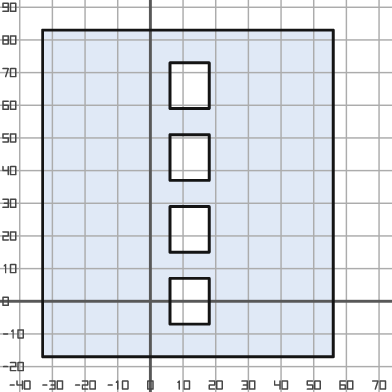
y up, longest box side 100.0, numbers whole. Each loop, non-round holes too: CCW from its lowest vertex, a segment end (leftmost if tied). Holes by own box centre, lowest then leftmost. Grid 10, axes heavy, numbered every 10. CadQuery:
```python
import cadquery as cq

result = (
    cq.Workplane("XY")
    .moveTo(-33.0, -17.0)
    .lineTo(56.0, -17.0)
    .lineTo(56.0, 83.0)
    .lineTo(-33.0, 83.0)
    .close()
    .moveTo(6.0, -7.0)
    .lineTo(18.0, -7.0)
    .lineTo(18.0, 7.0)
    .lineTo(6.0, 7.0)
    .close()
    .moveTo(6.0, 15.0)
    .lineTo(18.0, 15.0)
    .lineTo(18.0, 29.0)
    .lineTo(6.0, 29.0)
    .close()
    .moveTo(6.0, 37.0)
    .lineTo(18.0, 37.0)
    .lineTo(18.0, 51.0)
    .lineTo(6.0, 51.0)
    .close()
    .moveTo(6.0, 59.0)
    .lineTo(18.0, 59.0)
    .lineTo(18.0, 73.0)
    .lineTo(6.0, 73.0)
    .close()
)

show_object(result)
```